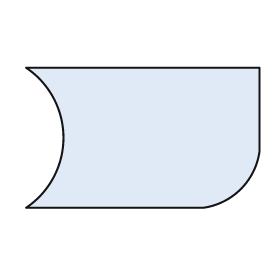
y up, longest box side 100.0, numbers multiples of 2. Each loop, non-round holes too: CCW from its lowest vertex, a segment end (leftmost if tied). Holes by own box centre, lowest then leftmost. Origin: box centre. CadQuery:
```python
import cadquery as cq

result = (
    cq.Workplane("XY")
    .moveTo(-50.0, -30.0)
    .lineTo(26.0, -30.0)
    .threePointArc((42.0, -22.0), (50.0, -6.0))
    .lineTo(50.0, 30.0)
    .lineTo(-50.0, 30.0)
    .threePointArc((-34.0, 0.0), (-50.0, -30.0))
    .close()
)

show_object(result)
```